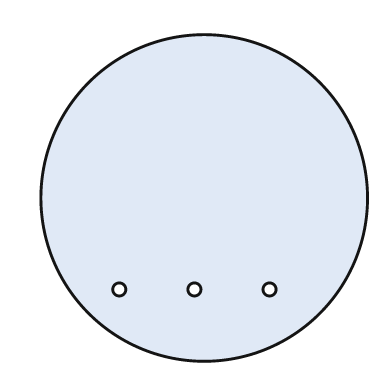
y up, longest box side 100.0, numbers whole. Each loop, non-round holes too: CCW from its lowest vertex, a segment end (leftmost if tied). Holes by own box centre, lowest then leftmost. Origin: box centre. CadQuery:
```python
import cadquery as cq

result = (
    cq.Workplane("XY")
    .moveTo(0.0, 0.0)
    .circle(50.0)
    .moveTo(-26.0, -28.0)
    .circle(2.0)
    .moveTo(-3.0, -28.0)
    .circle(2.0)
    .moveTo(20.0, -28.0)
    .circle(2.0)
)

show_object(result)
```